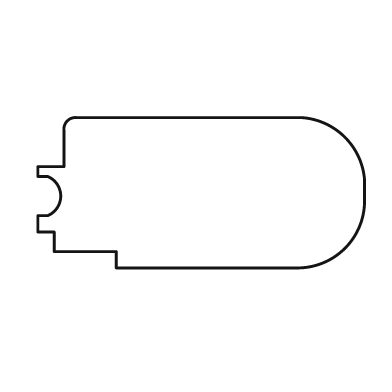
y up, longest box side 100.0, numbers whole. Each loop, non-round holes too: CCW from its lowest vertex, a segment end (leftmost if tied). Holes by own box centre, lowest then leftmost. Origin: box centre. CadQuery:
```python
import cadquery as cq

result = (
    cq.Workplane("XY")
    .moveTo(-26.0, -23.0)
    .lineTo(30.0, -23.0)
    .threePointArc((44.0, -17.0), (50.0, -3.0))
    .lineTo(50.0, 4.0)
    .threePointArc((44.0, 17.0), (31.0, 23.0))
    .lineTo(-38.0, 23.0)
    .threePointArc((-41.0, 22.0), (-42.0, 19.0))
    .lineTo(-42.0, 8.0)
    .lineTo(-50.0, 8.0)
    .lineTo(-50.0, 5.0)
    .lineTo(-47.0, 5.0)
    .threePointArc((-43.0, -1.0), (-47.0, -7.0))
    .lineTo(-50.0, -7.0)
    .lineTo(-50.0, -12.0)
    .lineTo(-45.0, -12.0)
    .lineTo(-45.0, -18.0)
    .lineTo(-26.0, -18.0)
    .close()
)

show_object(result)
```